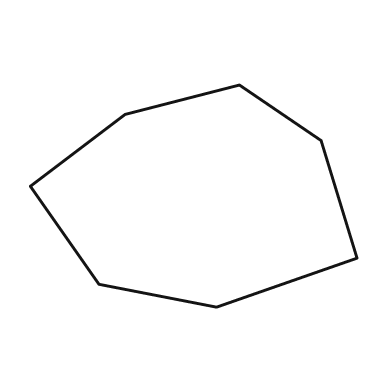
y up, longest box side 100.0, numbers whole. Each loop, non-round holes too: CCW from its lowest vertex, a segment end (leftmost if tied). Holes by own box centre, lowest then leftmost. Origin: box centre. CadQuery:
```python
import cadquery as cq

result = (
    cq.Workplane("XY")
    .moveTo(7.0, -34.0)
    .lineTo(50.0, -19.0)
    .lineTo(39.0, 17.0)
    .lineTo(14.0, 34.0)
    .lineTo(-21.0, 25.0)
    .lineTo(-50.0, 3.0)
    .lineTo(-29.0, -27.0)
    .close()
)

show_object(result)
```